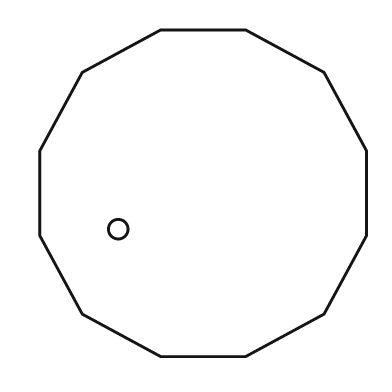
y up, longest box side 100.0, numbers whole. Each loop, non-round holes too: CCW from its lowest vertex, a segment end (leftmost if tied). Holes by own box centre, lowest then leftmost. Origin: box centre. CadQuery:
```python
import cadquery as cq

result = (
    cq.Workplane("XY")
    .moveTo(-13.0, -50.0)
    .lineTo(13.0, -50.0)
    .lineTo(37.0, -37.0)
    .lineTo(50.0, -13.0)
    .lineTo(50.0, 13.0)
    .lineTo(37.0, 37.0)
    .lineTo(13.0, 50.0)
    .lineTo(-13.0, 50.0)
    .lineTo(-37.0, 37.0)
    .lineTo(-50.0, 13.0)
    .lineTo(-50.0, -13.0)
    .lineTo(-37.0, -37.0)
    .close()
    .moveTo(-26.0, -11.0)
    .circle(3.0)
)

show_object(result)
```